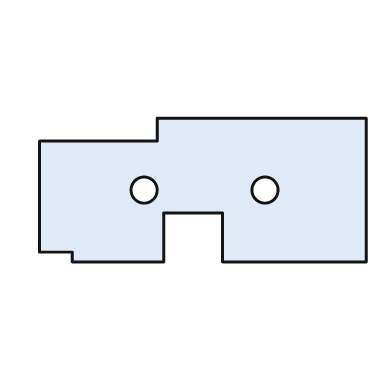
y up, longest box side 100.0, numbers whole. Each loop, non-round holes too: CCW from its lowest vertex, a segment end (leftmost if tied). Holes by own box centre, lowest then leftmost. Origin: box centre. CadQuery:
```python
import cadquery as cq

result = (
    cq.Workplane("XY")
    .moveTo(-40.0, -22.0)
    .lineTo(-12.0, -22.0)
    .lineTo(-12.0, -7.0)
    .lineTo(6.0, -7.0)
    .lineTo(6.0, -22.0)
    .lineTo(50.0, -22.0)
    .lineTo(50.0, 22.0)
    .lineTo(-14.0, 22.0)
    .lineTo(-14.0, 15.0)
    .lineTo(-50.0, 15.0)
    .lineTo(-50.0, -19.0)
    .lineTo(-40.0, -19.0)
    .close()
    .moveTo(-18.0, 0.0)
    .circle(4.0)
    .moveTo(19.0, 0.0)
    .circle(4.0)
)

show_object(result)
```